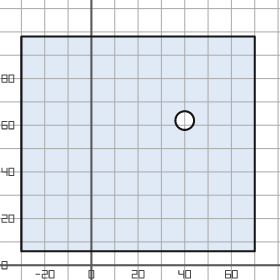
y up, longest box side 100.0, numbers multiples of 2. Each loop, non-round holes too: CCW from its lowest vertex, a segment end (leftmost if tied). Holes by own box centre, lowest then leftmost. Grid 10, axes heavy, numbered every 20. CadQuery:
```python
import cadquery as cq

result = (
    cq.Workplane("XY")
    .moveTo(-30.0, 6.0)
    .lineTo(70.0, 6.0)
    .lineTo(70.0, 98.0)
    .lineTo(-30.0, 98.0)
    .close()
    .moveTo(40.0, 62.0)
    .circle(4.0)
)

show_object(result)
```